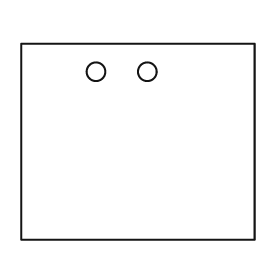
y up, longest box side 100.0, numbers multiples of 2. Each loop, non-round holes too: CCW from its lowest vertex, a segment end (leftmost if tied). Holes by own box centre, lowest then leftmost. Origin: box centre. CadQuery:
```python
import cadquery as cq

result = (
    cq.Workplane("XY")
    .moveTo(-50.0, -42.0)
    .lineTo(50.0, -42.0)
    .lineTo(50.0, 42.0)
    .lineTo(-50.0, 42.0)
    .close()
    .moveTo(-18.0, 30.0)
    .circle(4.0)
    .moveTo(4.0, 30.0)
    .circle(4.0)
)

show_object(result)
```